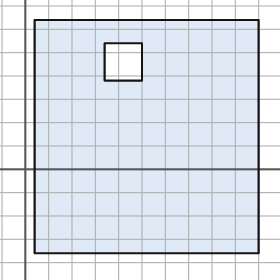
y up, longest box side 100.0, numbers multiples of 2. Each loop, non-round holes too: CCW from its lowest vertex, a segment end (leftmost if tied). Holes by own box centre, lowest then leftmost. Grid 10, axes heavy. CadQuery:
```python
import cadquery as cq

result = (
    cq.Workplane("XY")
    .moveTo(4.0, -36.0)
    .lineTo(100.0, -36.0)
    .lineTo(100.0, 64.0)
    .lineTo(4.0, 64.0)
    .close()
    .moveTo(34.0, 38.0)
    .lineTo(50.0, 38.0)
    .lineTo(50.0, 54.0)
    .lineTo(34.0, 54.0)
    .close()
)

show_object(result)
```